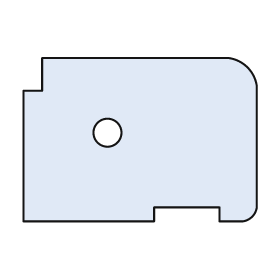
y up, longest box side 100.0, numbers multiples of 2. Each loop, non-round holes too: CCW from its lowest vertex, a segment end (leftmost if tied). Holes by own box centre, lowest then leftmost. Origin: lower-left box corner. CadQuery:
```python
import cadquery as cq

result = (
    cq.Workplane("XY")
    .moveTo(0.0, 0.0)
    .lineTo(56.0, 0.0)
    .lineTo(56.0, 6.0)
    .lineTo(84.0, 6.0)
    .lineTo(84.0, 0.0)
    .lineTo(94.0, 0.0)
    .threePointArc((98.0, 2.0), (100.0, 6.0))
    .lineTo(100.0, 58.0)
    .threePointArc((96.0, 66.0), (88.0, 70.0))
    .lineTo(8.0, 70.0)
    .lineTo(8.0, 56.0)
    .lineTo(0.0, 56.0)
    .close()
    .moveTo(36.0, 38.0)
    .circle(6.0)
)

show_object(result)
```